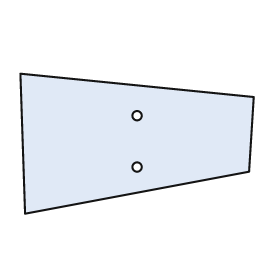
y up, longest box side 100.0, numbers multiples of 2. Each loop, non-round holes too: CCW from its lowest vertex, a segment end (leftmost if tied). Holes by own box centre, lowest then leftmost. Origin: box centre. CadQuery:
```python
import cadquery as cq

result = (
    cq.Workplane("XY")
    .moveTo(-48.0, -30.0)
    .lineTo(48.0, -12.0)
    .lineTo(50.0, 20.0)
    .lineTo(-50.0, 30.0)
    .close()
    .moveTo(0.0, -10.0)
    .circle(2.0)
    .moveTo(0.0, 12.0)
    .circle(2.0)
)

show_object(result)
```